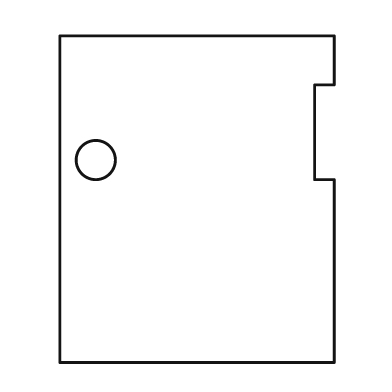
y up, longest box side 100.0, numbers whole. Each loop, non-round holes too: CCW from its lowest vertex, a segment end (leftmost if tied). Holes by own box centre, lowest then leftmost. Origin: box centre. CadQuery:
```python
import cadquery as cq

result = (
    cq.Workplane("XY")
    .moveTo(-42.0, -50.0)
    .lineTo(42.0, -50.0)
    .lineTo(42.0, 6.0)
    .lineTo(36.0, 6.0)
    .lineTo(36.0, 35.0)
    .lineTo(42.0, 35.0)
    .lineTo(42.0, 50.0)
    .lineTo(-42.0, 50.0)
    .close()
    .moveTo(-31.0, 12.0)
    .circle(6.0)
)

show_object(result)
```